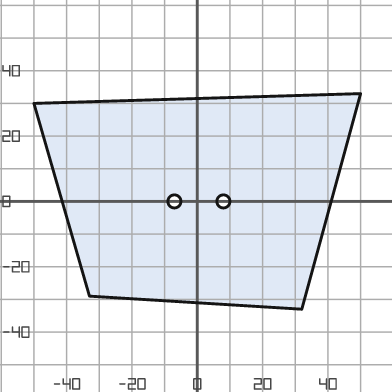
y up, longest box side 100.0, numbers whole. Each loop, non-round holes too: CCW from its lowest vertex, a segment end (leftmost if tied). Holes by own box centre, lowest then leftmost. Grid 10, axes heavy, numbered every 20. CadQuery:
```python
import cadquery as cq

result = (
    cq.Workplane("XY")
    .moveTo(32.0, -33.0)
    .lineTo(50.0, 33.0)
    .lineTo(-50.0, 30.0)
    .lineTo(-33.0, -29.0)
    .close()
    .moveTo(-7.0, 0.0)
    .circle(2.0)
    .moveTo(8.0, 0.0)
    .circle(2.0)
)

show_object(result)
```